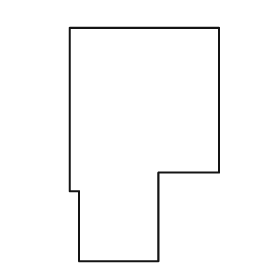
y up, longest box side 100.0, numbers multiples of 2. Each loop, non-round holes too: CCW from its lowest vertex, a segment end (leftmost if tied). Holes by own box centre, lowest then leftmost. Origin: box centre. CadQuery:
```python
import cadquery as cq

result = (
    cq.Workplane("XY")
    .moveTo(-28.0, -50.0)
    .lineTo(6.0, -50.0)
    .lineTo(6.0, -12.0)
    .lineTo(32.0, -12.0)
    .lineTo(32.0, 50.0)
    .lineTo(-32.0, 50.0)
    .lineTo(-32.0, -20.0)
    .lineTo(-28.0, -20.0)
    .close()
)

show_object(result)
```